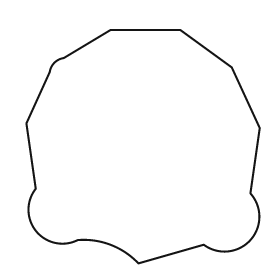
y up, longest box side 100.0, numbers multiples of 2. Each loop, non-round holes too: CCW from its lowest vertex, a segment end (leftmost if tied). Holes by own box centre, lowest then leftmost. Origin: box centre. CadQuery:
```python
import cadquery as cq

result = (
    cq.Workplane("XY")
    .moveTo(-2.0, -50.0)
    .lineTo(26.0, -42.0)
    .threePointArc((46.0, -40.0), (46.0, -20.0))
    .lineTo(50.0, 8.0)
    .lineTo(38.0, 34.0)
    .lineTo(16.0, 50.0)
    .lineTo(-14.0, 50.0)
    .lineTo(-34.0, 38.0)
    .threePointArc((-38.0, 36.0), (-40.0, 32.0))
    .lineTo(-50.0, 10.0)
    .lineTo(-46.0, -18.0)
    .threePointArc((-46.0, -36.0), (-28.0, -40.0))
    .threePointArc((-14.0, -42.0), (-2.0, -50.0))
    .close()
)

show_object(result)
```